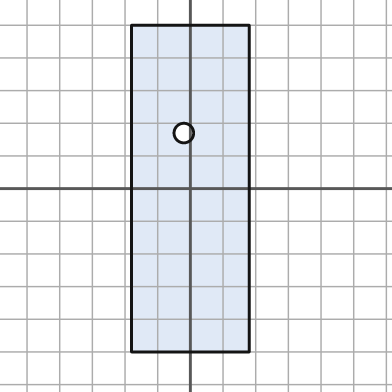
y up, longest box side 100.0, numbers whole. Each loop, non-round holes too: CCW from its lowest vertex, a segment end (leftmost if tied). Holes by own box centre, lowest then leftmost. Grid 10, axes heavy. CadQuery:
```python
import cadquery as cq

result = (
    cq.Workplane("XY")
    .moveTo(-18.0, -50.0)
    .lineTo(18.0, -50.0)
    .lineTo(18.0, 50.0)
    .lineTo(-18.0, 50.0)
    .close()
    .moveTo(-2.0, 17.0)
    .circle(3.0)
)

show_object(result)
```